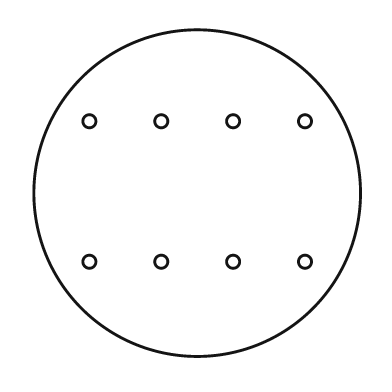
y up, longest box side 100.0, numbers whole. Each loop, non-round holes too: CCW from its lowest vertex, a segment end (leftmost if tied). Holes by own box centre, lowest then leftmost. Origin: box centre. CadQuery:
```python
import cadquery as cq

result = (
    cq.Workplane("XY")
    .moveTo(0.0, 0.0)
    .circle(50.0)
    .moveTo(-33.0, -21.0)
    .circle(2.0)
    .moveTo(-11.0, -21.0)
    .circle(2.0)
    .moveTo(11.0, -21.0)
    .circle(2.0)
    .moveTo(33.0, -21.0)
    .circle(2.0)
    .moveTo(-33.0, 22.0)
    .circle(2.0)
    .moveTo(-11.0, 22.0)
    .circle(2.0)
    .moveTo(11.0, 22.0)
    .circle(2.0)
    .moveTo(33.0, 22.0)
    .circle(2.0)
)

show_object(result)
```